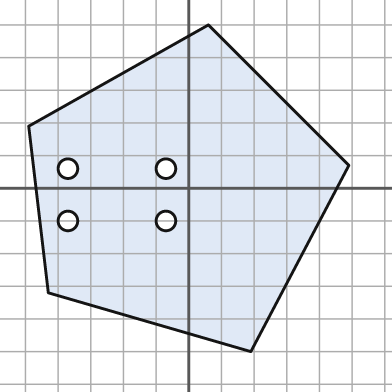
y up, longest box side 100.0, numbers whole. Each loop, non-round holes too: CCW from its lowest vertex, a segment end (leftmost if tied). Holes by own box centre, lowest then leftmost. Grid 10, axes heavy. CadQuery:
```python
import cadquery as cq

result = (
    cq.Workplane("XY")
    .moveTo(19.0, -50.0)
    .lineTo(49.0, 7.0)
    .lineTo(6.0, 50.0)
    .lineTo(-49.0, 19.0)
    .lineTo(-43.0, -32.0)
    .close()
    .moveTo(-37.0, -10.0)
    .circle(3.0)
    .moveTo(-7.0, -10.0)
    .circle(3.0)
    .moveTo(-37.0, 6.0)
    .circle(3.0)
    .moveTo(-7.0, 6.0)
    .circle(3.0)
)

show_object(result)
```